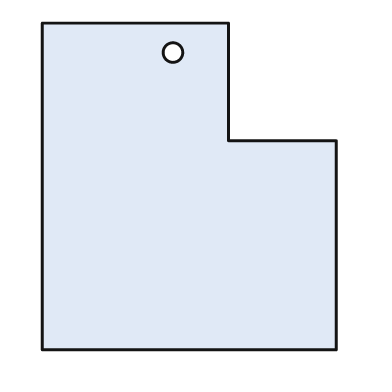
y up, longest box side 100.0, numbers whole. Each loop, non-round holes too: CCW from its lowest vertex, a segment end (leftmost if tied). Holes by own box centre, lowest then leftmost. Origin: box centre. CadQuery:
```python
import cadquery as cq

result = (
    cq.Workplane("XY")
    .moveTo(-45.0, -50.0)
    .lineTo(45.0, -50.0)
    .lineTo(45.0, 14.0)
    .lineTo(12.0, 14.0)
    .lineTo(12.0, 50.0)
    .lineTo(-45.0, 50.0)
    .close()
    .moveTo(-5.0, 41.0)
    .circle(3.0)
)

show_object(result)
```